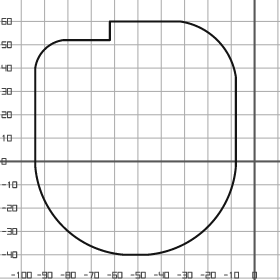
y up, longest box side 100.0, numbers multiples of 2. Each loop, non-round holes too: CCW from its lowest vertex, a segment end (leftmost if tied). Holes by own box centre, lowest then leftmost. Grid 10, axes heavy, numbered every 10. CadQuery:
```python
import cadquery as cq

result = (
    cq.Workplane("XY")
    .moveTo(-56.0, -40.0)
    .lineTo(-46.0, -40.0)
    .threePointArc((-20.0, -28.0), (-8.0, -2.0))
    .lineTo(-8.0, 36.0)
    .threePointArc((-16.0, 52.0), (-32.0, 60.0))
    .lineTo(-62.0, 60.0)
    .lineTo(-62.0, 52.0)
    .lineTo(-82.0, 52.0)
    .threePointArc((-90.0, 48.0), (-94.0, 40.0))
    .lineTo(-94.0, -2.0)
    .threePointArc((-82.0, -28.0), (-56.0, -40.0))
    .close()
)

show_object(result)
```